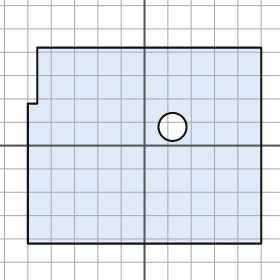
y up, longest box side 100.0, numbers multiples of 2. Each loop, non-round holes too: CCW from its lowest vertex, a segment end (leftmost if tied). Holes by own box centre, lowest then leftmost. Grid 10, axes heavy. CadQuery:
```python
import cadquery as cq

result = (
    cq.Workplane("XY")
    .moveTo(-50.0, -42.0)
    .lineTo(50.0, -42.0)
    .lineTo(50.0, 42.0)
    .lineTo(-46.0, 42.0)
    .lineTo(-46.0, 18.0)
    .lineTo(-50.0, 18.0)
    .close()
    .moveTo(12.0, 8.0)
    .circle(6.0)
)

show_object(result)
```